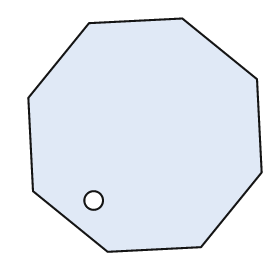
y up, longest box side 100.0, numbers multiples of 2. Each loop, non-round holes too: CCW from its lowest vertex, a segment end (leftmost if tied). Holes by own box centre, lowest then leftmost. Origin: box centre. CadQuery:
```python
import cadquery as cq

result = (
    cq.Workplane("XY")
    .moveTo(-16.0, -50.0)
    .lineTo(24.0, -48.0)
    .lineTo(50.0, -16.0)
    .lineTo(48.0, 24.0)
    .lineTo(16.0, 50.0)
    .lineTo(-24.0, 48.0)
    .lineTo(-50.0, 16.0)
    .lineTo(-48.0, -24.0)
    .close()
    .moveTo(-22.0, -28.0)
    .circle(4.0)
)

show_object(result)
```